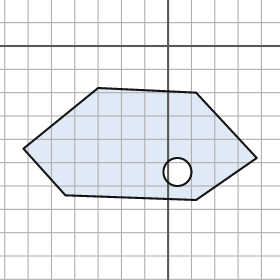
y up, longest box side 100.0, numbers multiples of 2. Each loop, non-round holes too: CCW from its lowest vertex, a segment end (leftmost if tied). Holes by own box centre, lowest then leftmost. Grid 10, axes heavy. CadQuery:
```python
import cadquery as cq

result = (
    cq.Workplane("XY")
    .moveTo(12.0, -66.0)
    .lineTo(38.0, -48.0)
    .lineTo(12.0, -20.0)
    .lineTo(-30.0, -18.0)
    .lineTo(-62.0, -44.0)
    .lineTo(-44.0, -64.0)
    .close()
    .moveTo(4.0, -54.0)
    .circle(6.0)
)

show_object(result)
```